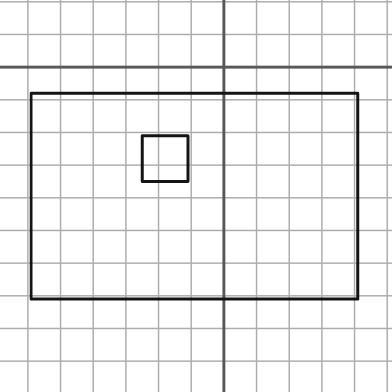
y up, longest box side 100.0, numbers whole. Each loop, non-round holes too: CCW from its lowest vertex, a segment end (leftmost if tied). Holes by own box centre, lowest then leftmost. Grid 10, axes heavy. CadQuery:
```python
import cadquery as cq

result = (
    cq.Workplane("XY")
    .moveTo(-59.0, -71.0)
    .lineTo(41.0, -71.0)
    .lineTo(41.0, -8.0)
    .lineTo(-59.0, -8.0)
    .close()
    .moveTo(-25.0, -35.0)
    .lineTo(-11.0, -35.0)
    .lineTo(-11.0, -21.0)
    .lineTo(-25.0, -21.0)
    .close()
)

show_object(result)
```